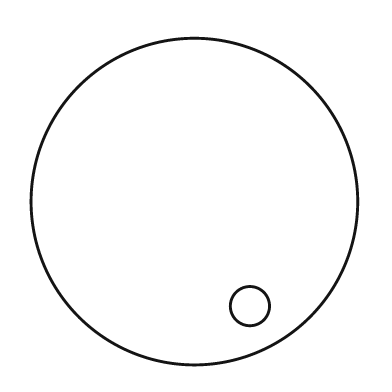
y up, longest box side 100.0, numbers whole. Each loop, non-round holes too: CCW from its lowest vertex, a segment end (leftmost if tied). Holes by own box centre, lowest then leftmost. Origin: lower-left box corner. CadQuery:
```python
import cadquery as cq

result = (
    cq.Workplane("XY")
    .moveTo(50.0, 50.0)
    .circle(50.0)
    .moveTo(67.0, 18.0)
    .circle(6.0)
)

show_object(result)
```